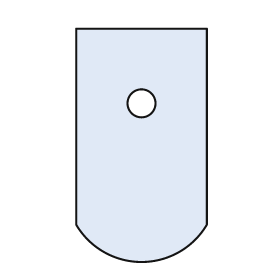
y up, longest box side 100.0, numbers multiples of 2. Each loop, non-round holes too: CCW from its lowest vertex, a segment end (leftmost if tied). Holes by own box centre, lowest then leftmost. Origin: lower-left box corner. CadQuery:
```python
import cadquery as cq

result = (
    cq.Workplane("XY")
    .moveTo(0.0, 16.0)
    .threePointArc((28.0, 0.0), (56.0, 16.0))
    .lineTo(56.0, 100.0)
    .lineTo(0.0, 100.0)
    .close()
    .moveTo(28.0, 68.0)
    .circle(6.0)
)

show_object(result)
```